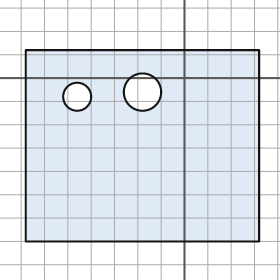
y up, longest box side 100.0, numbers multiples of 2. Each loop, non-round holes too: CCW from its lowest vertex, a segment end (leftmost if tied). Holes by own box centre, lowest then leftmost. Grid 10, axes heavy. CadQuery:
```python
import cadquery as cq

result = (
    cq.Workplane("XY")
    .moveTo(-68.0, -70.0)
    .lineTo(32.0, -70.0)
    .lineTo(32.0, 12.0)
    .lineTo(-68.0, 12.0)
    .close()
    .moveTo(-46.0, -8.0)
    .circle(6.0)
    .moveTo(-18.0, -6.0)
    .circle(8.0)
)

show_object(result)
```